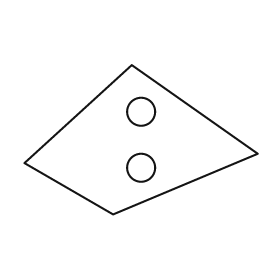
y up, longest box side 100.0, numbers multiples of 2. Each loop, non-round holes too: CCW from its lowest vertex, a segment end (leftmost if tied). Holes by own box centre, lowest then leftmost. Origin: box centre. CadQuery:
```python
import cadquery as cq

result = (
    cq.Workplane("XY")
    .moveTo(-12.0, -32.0)
    .lineTo(50.0, -6.0)
    .lineTo(-4.0, 32.0)
    .lineTo(-50.0, -10.0)
    .close()
    .moveTo(0.0, -12.0)
    .circle(6.0)
    .moveTo(0.0, 12.0)
    .circle(6.0)
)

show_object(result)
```